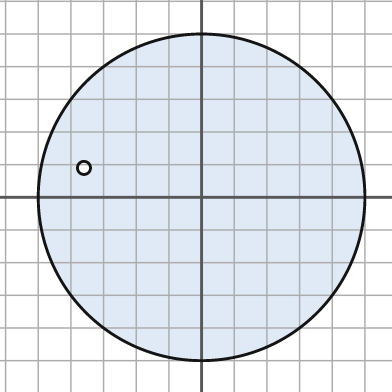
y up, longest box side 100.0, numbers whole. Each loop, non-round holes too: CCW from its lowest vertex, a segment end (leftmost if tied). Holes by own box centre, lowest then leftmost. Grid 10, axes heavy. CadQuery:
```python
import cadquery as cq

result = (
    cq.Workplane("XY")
    .moveTo(0.0, 0.0)
    .circle(50.0)
    .moveTo(-36.0, 9.0)
    .circle(2.0)
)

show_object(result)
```